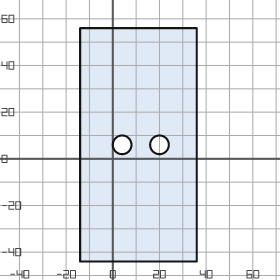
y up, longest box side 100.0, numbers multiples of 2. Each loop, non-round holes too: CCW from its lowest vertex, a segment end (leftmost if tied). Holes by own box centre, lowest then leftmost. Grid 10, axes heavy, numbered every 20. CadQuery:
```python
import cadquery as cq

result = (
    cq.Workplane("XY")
    .moveTo(-14.0, -44.0)
    .lineTo(36.0, -44.0)
    .lineTo(36.0, 56.0)
    .lineTo(-14.0, 56.0)
    .close()
    .moveTo(4.0, 6.0)
    .circle(4.0)
    .moveTo(20.0, 6.0)
    .circle(4.0)
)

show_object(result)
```